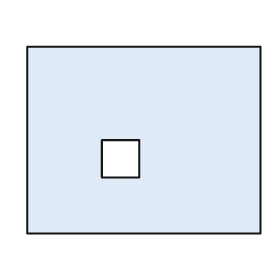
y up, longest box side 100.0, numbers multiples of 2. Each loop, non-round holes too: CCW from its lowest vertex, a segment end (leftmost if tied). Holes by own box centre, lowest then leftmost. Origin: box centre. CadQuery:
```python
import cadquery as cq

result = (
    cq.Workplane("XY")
    .moveTo(-50.0, -40.0)
    .lineTo(50.0, -40.0)
    .lineTo(50.0, 40.0)
    .lineTo(-50.0, 40.0)
    .close()
    .moveTo(-18.0, -16.0)
    .lineTo(-2.0, -16.0)
    .lineTo(-2.0, 0.0)
    .lineTo(-18.0, 0.0)
    .close()
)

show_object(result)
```